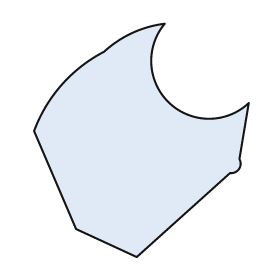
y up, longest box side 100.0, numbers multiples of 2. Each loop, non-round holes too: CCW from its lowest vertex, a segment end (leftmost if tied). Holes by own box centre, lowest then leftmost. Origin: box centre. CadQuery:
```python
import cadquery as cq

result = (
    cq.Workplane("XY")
    .moveTo(-2.0, -50.0)
    .lineTo(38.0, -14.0)
    .threePointArc((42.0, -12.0), (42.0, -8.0))
    .lineTo(46.0, 16.0)
    .threePointArc((12.0, 16.0), (10.0, 50.0))
    .threePointArc((-4.0, 46.0), (-16.0, 38.0))
    .threePointArc((-34.0, 24.0), (-46.0, 4.0))
    .lineTo(-28.0, -38.0)
    .close()
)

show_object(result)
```